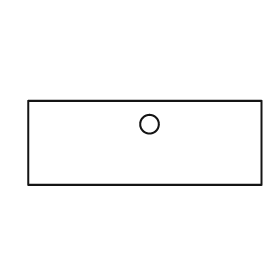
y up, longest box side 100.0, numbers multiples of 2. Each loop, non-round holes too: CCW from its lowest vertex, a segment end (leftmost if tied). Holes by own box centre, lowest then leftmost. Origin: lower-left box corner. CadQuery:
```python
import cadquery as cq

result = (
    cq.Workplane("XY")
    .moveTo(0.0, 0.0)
    .lineTo(100.0, 0.0)
    .lineTo(100.0, 36.0)
    .lineTo(0.0, 36.0)
    .close()
    .moveTo(52.0, 26.0)
    .circle(4.0)
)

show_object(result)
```